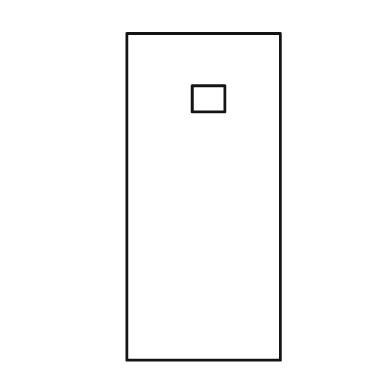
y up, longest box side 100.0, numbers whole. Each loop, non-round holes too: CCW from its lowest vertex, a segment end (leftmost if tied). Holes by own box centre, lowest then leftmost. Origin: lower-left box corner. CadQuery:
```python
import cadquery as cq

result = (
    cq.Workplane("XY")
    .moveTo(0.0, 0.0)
    .lineTo(47.0, 0.0)
    .lineTo(47.0, 100.0)
    .lineTo(0.0, 100.0)
    .close()
    .moveTo(20.0, 76.0)
    .lineTo(30.0, 76.0)
    .lineTo(30.0, 84.0)
    .lineTo(20.0, 84.0)
    .close()
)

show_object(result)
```